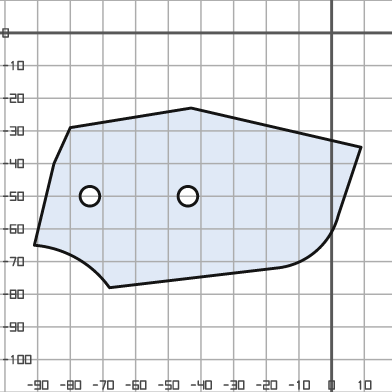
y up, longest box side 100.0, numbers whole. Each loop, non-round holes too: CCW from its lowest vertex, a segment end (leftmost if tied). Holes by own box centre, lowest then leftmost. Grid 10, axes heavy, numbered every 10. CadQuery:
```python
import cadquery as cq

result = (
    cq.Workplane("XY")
    .moveTo(-68.0, -78.0)
    .lineTo(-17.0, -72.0)
    .threePointArc((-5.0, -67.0), (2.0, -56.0))
    .lineTo(9.0, -35.0)
    .lineTo(-43.0, -23.0)
    .lineTo(-80.0, -29.0)
    .lineTo(-85.0, -40.0)
    .lineTo(-91.0, -65.0)
    .threePointArc((-78.0, -69.0), (-68.0, -78.0))
    .close()
    .moveTo(-74.0, -50.0)
    .circle(3.0)
    .moveTo(-44.0, -50.0)
    .circle(3.0)
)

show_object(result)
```